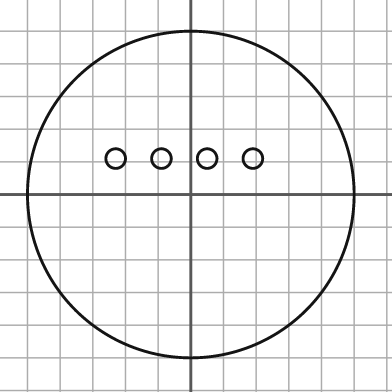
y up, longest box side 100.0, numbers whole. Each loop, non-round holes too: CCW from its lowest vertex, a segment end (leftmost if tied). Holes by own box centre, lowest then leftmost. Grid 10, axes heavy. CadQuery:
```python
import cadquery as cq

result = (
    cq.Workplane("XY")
    .moveTo(0.0, 0.0)
    .circle(50.0)
    .moveTo(-23.0, 11.0)
    .circle(3.0)
    .moveTo(-9.0, 11.0)
    .circle(3.0)
    .moveTo(5.0, 11.0)
    .circle(3.0)
    .moveTo(19.0, 11.0)
    .circle(3.0)
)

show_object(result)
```